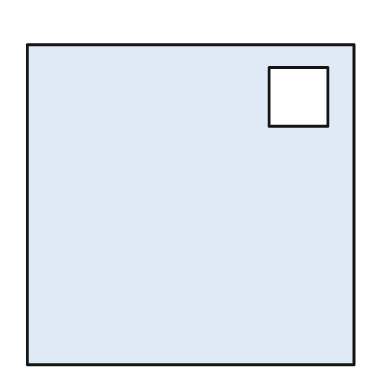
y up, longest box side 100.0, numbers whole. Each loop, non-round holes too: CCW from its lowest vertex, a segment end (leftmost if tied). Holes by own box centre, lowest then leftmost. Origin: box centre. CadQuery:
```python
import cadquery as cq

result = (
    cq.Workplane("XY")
    .moveTo(-50.0, -49.0)
    .lineTo(50.0, -49.0)
    .lineTo(50.0, 49.0)
    .lineTo(-50.0, 49.0)
    .close()
    .moveTo(24.0, 24.0)
    .lineTo(42.0, 24.0)
    .lineTo(42.0, 42.0)
    .lineTo(24.0, 42.0)
    .close()
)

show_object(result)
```